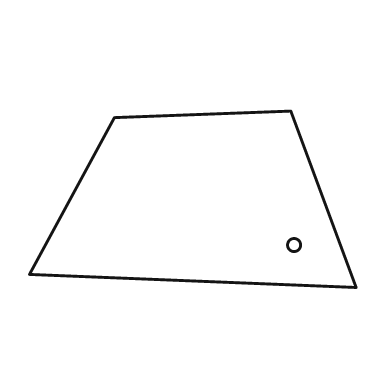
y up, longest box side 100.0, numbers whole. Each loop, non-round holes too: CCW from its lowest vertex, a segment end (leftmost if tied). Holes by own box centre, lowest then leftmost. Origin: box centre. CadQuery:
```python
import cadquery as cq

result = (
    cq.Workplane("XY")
    .moveTo(50.0, -27.0)
    .lineTo(30.0, 27.0)
    .lineTo(-24.0, 25.0)
    .lineTo(-50.0, -23.0)
    .close()
    .moveTo(31.0, -14.0)
    .circle(2.0)
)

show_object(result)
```